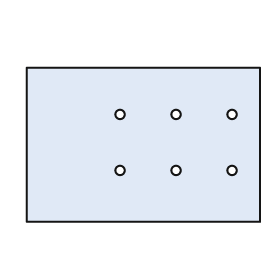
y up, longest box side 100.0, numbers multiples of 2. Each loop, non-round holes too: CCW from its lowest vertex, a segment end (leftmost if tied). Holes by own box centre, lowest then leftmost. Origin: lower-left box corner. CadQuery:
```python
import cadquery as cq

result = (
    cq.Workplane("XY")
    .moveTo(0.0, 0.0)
    .lineTo(100.0, 0.0)
    .lineTo(100.0, 66.0)
    .lineTo(0.0, 66.0)
    .close()
    .moveTo(40.0, 22.0)
    .circle(2.0)
    .moveTo(64.0, 22.0)
    .circle(2.0)
    .moveTo(88.0, 22.0)
    .circle(2.0)
    .moveTo(40.0, 46.0)
    .circle(2.0)
    .moveTo(64.0, 46.0)
    .circle(2.0)
    .moveTo(88.0, 46.0)
    .circle(2.0)
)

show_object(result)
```